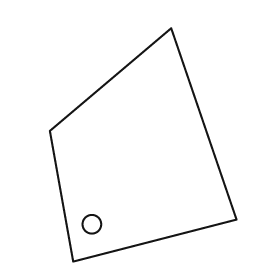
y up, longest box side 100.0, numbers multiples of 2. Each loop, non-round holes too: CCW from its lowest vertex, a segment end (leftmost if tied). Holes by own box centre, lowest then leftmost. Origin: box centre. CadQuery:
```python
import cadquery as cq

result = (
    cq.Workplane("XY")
    .moveTo(-30.0, -50.0)
    .lineTo(40.0, -32.0)
    .lineTo(12.0, 50.0)
    .lineTo(-40.0, 6.0)
    .close()
    .moveTo(-22.0, -34.0)
    .circle(4.0)
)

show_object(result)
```